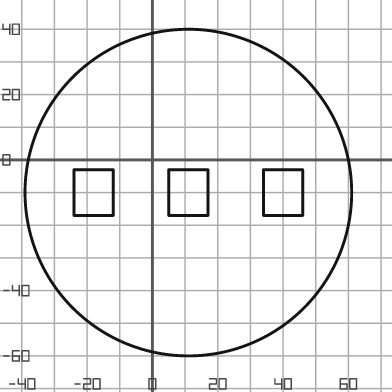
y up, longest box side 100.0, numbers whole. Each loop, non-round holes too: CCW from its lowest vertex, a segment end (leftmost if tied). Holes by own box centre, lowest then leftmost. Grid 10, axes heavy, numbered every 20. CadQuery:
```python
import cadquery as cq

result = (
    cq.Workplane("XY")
    .moveTo(11.0, -10.0)
    .circle(50.0)
    .moveTo(-24.0, -17.0)
    .lineTo(-12.0, -17.0)
    .lineTo(-12.0, -3.0)
    .lineTo(-24.0, -3.0)
    .close()
    .moveTo(5.0, -17.0)
    .lineTo(17.0, -17.0)
    .lineTo(17.0, -3.0)
    .lineTo(5.0, -3.0)
    .close()
    .moveTo(34.0, -17.0)
    .lineTo(46.0, -17.0)
    .lineTo(46.0, -3.0)
    .lineTo(34.0, -3.0)
    .close()
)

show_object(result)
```